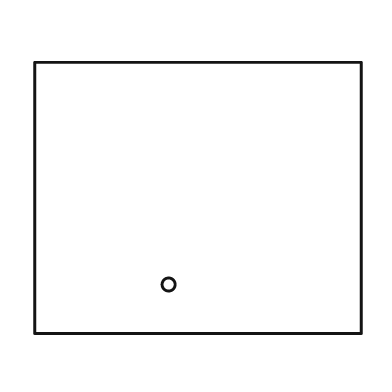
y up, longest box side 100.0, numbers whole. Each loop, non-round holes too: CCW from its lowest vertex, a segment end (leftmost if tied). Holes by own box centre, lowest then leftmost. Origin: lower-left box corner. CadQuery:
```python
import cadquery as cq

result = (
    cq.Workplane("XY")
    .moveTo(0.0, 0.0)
    .lineTo(100.0, 0.0)
    .lineTo(100.0, 83.0)
    .lineTo(0.0, 83.0)
    .close()
    .moveTo(41.0, 15.0)
    .circle(2.0)
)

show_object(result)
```